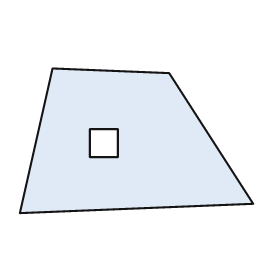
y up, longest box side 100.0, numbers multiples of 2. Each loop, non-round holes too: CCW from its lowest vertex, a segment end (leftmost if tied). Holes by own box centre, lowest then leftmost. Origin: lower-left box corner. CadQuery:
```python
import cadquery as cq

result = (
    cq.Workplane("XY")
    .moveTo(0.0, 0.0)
    .lineTo(100.0, 4.0)
    .lineTo(64.0, 60.0)
    .lineTo(14.0, 62.0)
    .close()
    .moveTo(30.0, 24.0)
    .lineTo(42.0, 24.0)
    .lineTo(42.0, 36.0)
    .lineTo(30.0, 36.0)
    .close()
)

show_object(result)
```